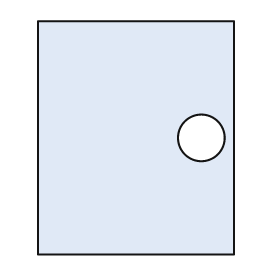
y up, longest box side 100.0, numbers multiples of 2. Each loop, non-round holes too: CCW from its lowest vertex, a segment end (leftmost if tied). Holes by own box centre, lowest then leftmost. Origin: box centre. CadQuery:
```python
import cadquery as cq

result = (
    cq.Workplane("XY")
    .moveTo(-42.0, -50.0)
    .lineTo(42.0, -50.0)
    .lineTo(42.0, 50.0)
    .lineTo(-42.0, 50.0)
    .close()
    .moveTo(28.0, 0.0)
    .circle(10.0)
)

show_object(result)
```